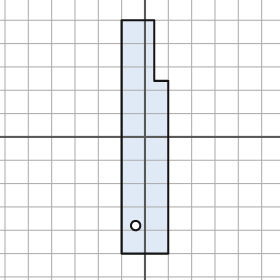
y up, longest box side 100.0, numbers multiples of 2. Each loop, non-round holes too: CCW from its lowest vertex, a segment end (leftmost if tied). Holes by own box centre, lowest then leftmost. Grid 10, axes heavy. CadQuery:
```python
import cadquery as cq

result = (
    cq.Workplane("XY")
    .moveTo(-10.0, -50.0)
    .lineTo(10.0, -50.0)
    .lineTo(10.0, 24.0)
    .lineTo(4.0, 24.0)
    .lineTo(4.0, 50.0)
    .lineTo(-10.0, 50.0)
    .close()
    .moveTo(-4.0, -38.0)
    .circle(2.0)
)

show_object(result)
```